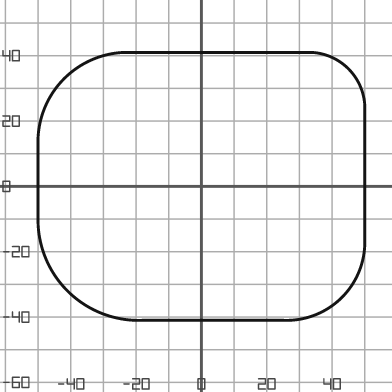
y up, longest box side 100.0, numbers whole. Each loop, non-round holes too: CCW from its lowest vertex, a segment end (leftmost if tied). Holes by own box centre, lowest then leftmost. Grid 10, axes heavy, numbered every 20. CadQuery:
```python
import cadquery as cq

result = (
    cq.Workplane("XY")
    .moveTo(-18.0, -41.0)
    .lineTo(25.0, -41.0)
    .threePointArc((43.0, -34.0), (50.0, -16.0))
    .lineTo(50.0, 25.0)
    .threePointArc((45.0, 36.0), (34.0, 41.0))
    .lineTo(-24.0, 41.0)
    .threePointArc((-42.0, 33.0), (-50.0, 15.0))
    .lineTo(-50.0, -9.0)
    .threePointArc((-41.0, -32.0), (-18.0, -41.0))
    .close()
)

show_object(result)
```